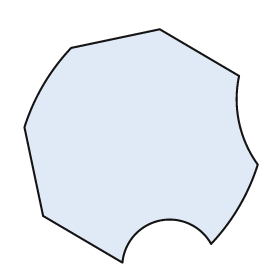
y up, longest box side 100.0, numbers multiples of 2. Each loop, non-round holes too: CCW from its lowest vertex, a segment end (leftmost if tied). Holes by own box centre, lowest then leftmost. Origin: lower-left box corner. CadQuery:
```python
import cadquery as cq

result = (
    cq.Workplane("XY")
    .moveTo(42.0, 0.0)
    .threePointArc((58.0, 18.0), (80.0, 8.0))
    .threePointArc((92.0, 24.0), (100.0, 42.0))
    .threePointArc((92.0, 60.0), (92.0, 80.0))
    .lineTo(58.0, 100.0)
    .lineTo(20.0, 92.0)
    .threePointArc((8.0, 76.0), (0.0, 58.0))
    .lineTo(8.0, 20.0)
    .close()
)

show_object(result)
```